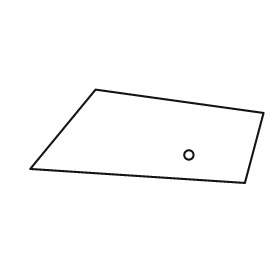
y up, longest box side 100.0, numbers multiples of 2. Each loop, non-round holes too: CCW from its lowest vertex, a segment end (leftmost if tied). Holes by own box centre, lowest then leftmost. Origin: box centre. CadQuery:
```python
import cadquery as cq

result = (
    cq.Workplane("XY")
    .moveTo(42.0, -20.0)
    .lineTo(50.0, 10.0)
    .lineTo(-22.0, 20.0)
    .lineTo(-50.0, -14.0)
    .close()
    .moveTo(18.0, -8.0)
    .circle(2.0)
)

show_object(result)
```